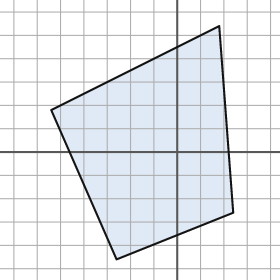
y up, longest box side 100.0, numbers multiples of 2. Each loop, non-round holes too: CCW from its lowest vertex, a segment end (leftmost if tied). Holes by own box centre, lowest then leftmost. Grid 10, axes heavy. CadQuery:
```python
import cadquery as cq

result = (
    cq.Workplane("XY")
    .moveTo(-26.0, -46.0)
    .lineTo(24.0, -26.0)
    .lineTo(18.0, 54.0)
    .lineTo(-54.0, 18.0)
    .close()
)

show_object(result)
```